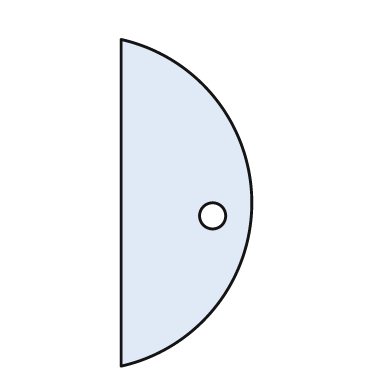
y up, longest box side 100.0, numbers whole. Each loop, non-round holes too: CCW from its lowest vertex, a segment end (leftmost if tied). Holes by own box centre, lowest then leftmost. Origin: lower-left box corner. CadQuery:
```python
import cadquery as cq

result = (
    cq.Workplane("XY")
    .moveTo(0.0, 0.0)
    .threePointArc((40.0, 50.0), (0.0, 100.0))
    .close()
    .moveTo(28.0, 46.0)
    .circle(4.0)
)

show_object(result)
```